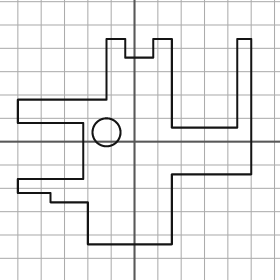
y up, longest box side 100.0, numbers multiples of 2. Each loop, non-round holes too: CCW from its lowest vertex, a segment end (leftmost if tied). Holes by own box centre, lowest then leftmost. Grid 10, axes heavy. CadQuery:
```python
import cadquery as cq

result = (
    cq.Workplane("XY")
    .moveTo(-20.0, -44.0)
    .lineTo(16.0, -44.0)
    .lineTo(16.0, -14.0)
    .lineTo(50.0, -14.0)
    .lineTo(50.0, 44.0)
    .lineTo(44.0, 44.0)
    .lineTo(44.0, 6.0)
    .lineTo(16.0, 6.0)
    .lineTo(16.0, 44.0)
    .lineTo(8.0, 44.0)
    .lineTo(8.0, 36.0)
    .lineTo(-4.0, 36.0)
    .lineTo(-4.0, 44.0)
    .lineTo(-12.0, 44.0)
    .lineTo(-12.0, 18.0)
    .lineTo(-50.0, 18.0)
    .lineTo(-50.0, 8.0)
    .lineTo(-22.0, 8.0)
    .lineTo(-22.0, -16.0)
    .lineTo(-50.0, -16.0)
    .lineTo(-50.0, -22.0)
    .lineTo(-36.0, -22.0)
    .lineTo(-36.0, -26.0)
    .lineTo(-20.0, -26.0)
    .close()
    .moveTo(-12.0, 4.0)
    .circle(6.0)
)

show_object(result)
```